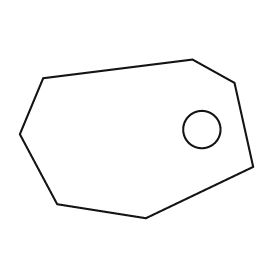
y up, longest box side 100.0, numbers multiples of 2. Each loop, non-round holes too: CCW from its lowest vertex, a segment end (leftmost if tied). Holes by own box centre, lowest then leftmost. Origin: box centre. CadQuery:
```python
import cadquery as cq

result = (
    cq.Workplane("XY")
    .moveTo(4.0, -34.0)
    .lineTo(50.0, -12.0)
    .lineTo(42.0, 24.0)
    .lineTo(24.0, 34.0)
    .lineTo(-40.0, 26.0)
    .lineTo(-50.0, 2.0)
    .lineTo(-34.0, -28.0)
    .close()
    .moveTo(28.0, 4.0)
    .circle(8.0)
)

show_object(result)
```